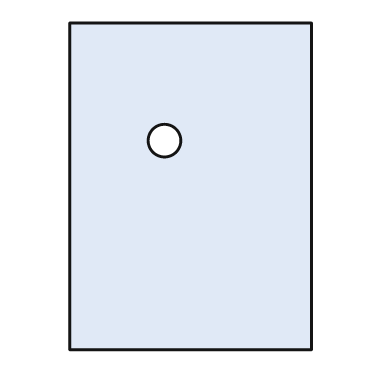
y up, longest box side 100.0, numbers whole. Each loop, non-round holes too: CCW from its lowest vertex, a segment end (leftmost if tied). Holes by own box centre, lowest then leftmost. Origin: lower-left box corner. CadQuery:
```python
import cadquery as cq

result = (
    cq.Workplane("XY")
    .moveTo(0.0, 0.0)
    .lineTo(74.0, 0.0)
    .lineTo(74.0, 100.0)
    .lineTo(0.0, 100.0)
    .close()
    .moveTo(29.0, 64.0)
    .circle(5.0)
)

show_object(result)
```